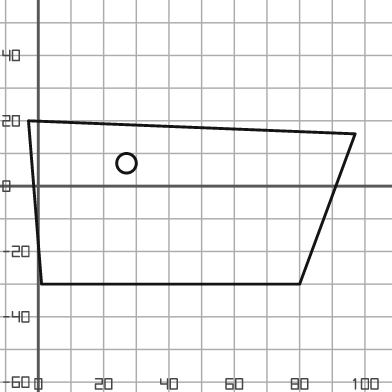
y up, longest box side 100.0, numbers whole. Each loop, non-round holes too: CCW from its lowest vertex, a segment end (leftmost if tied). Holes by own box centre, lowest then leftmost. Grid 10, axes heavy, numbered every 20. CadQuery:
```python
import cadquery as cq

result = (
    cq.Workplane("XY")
    .moveTo(1.0, -30.0)
    .lineTo(80.0, -30.0)
    .lineTo(97.0, 16.0)
    .lineTo(-3.0, 20.0)
    .close()
    .moveTo(27.0, 7.0)
    .circle(3.0)
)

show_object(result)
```